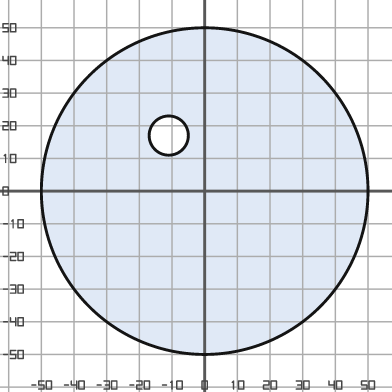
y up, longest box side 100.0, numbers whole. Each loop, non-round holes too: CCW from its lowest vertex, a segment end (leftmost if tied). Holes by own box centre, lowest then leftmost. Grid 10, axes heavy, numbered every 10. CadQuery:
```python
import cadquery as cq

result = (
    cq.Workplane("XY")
    .moveTo(0.0, 0.0)
    .circle(50.0)
    .moveTo(-11.0, 17.0)
    .circle(6.0)
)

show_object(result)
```